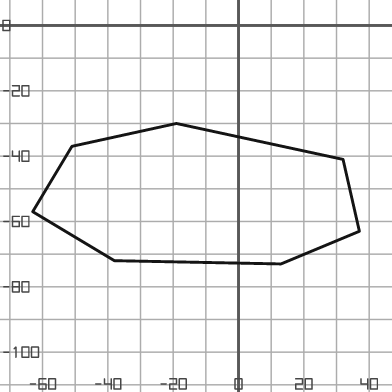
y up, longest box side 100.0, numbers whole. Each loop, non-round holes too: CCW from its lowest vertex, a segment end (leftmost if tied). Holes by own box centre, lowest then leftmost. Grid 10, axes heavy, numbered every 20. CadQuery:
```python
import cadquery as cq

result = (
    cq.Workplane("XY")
    .moveTo(13.0, -73.0)
    .lineTo(37.0, -63.0)
    .lineTo(32.0, -41.0)
    .lineTo(-19.0, -30.0)
    .lineTo(-51.0, -37.0)
    .lineTo(-63.0, -57.0)
    .lineTo(-38.0, -72.0)
    .close()
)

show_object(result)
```